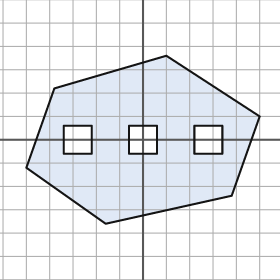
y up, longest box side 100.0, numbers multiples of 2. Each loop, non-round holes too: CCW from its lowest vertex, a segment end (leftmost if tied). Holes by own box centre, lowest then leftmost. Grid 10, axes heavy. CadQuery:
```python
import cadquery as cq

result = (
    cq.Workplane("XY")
    .moveTo(-16.0, -36.0)
    .lineTo(38.0, -24.0)
    .lineTo(50.0, 10.0)
    .lineTo(10.0, 36.0)
    .lineTo(-38.0, 22.0)
    .lineTo(-50.0, -12.0)
    .close()
    .moveTo(-34.0, -6.0)
    .lineTo(-22.0, -6.0)
    .lineTo(-22.0, 6.0)
    .lineTo(-34.0, 6.0)
    .close()
    .moveTo(-6.0, -6.0)
    .lineTo(6.0, -6.0)
    .lineTo(6.0, 6.0)
    .lineTo(-6.0, 6.0)
    .close()
    .moveTo(22.0, -6.0)
    .lineTo(34.0, -6.0)
    .lineTo(34.0, 6.0)
    .lineTo(22.0, 6.0)
    .close()
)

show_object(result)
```